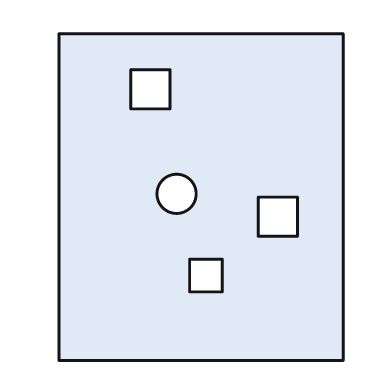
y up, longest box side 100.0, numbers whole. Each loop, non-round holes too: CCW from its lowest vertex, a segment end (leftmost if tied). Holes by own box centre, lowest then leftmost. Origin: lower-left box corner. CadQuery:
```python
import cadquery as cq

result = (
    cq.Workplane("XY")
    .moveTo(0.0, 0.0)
    .lineTo(87.0, 0.0)
    .lineTo(87.0, 100.0)
    .lineTo(0.0, 100.0)
    .close()
    .moveTo(40.0, 21.0)
    .lineTo(50.0, 21.0)
    .lineTo(50.0, 31.0)
    .lineTo(40.0, 31.0)
    .close()
    .moveTo(61.0, 38.0)
    .lineTo(73.0, 38.0)
    .lineTo(73.0, 50.0)
    .lineTo(61.0, 50.0)
    .close()
    .moveTo(36.0, 51.0)
    .circle(6.0)
    .moveTo(22.0, 77.0)
    .lineTo(34.0, 77.0)
    .lineTo(34.0, 89.0)
    .lineTo(22.0, 89.0)
    .close()
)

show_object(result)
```